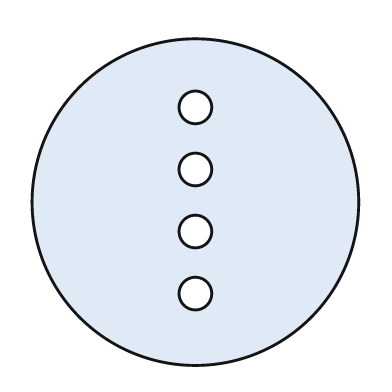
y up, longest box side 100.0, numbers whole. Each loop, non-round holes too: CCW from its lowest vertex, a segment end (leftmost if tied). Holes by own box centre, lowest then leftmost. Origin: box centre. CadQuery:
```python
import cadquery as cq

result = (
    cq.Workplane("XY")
    .moveTo(0.0, 0.0)
    .circle(50.0)
    .moveTo(0.0, -28.0)
    .circle(5.0)
    .moveTo(0.0, -9.0)
    .circle(5.0)
    .moveTo(0.0, 10.0)
    .circle(5.0)
    .moveTo(0.0, 29.0)
    .circle(5.0)
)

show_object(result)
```